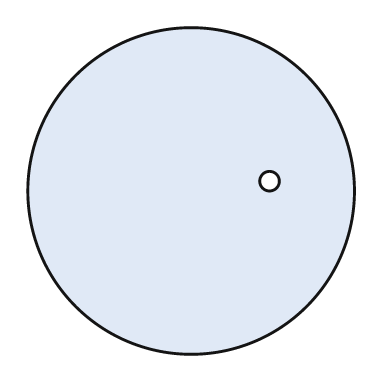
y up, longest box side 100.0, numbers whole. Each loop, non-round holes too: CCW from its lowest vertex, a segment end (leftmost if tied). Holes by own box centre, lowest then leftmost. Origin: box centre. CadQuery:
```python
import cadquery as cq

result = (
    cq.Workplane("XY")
    .moveTo(0.0, 0.0)
    .circle(50.0)
    .moveTo(24.0, 3.0)
    .circle(3.0)
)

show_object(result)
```